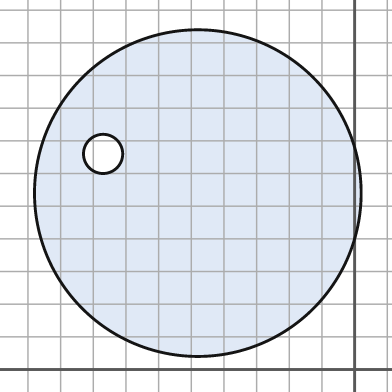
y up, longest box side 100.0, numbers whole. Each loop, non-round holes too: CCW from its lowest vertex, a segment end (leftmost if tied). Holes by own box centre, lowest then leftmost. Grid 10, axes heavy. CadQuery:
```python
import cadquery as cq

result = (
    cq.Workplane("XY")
    .moveTo(-48.0, 54.0)
    .circle(50.0)
    .moveTo(-77.0, 66.0)
    .circle(6.0)
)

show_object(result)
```